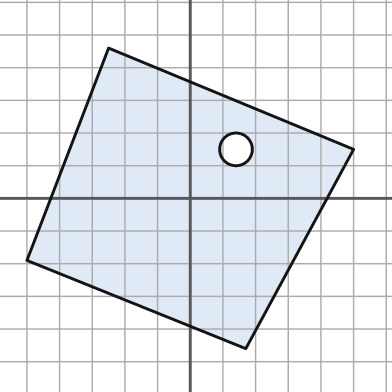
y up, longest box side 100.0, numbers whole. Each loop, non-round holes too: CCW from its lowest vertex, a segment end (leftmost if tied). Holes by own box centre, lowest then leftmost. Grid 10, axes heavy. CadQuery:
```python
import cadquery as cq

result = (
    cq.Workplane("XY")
    .moveTo(17.0, -46.0)
    .lineTo(50.0, 15.0)
    .lineTo(-25.0, 46.0)
    .lineTo(-50.0, -19.0)
    .close()
    .moveTo(14.0, 15.0)
    .circle(5.0)
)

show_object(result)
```